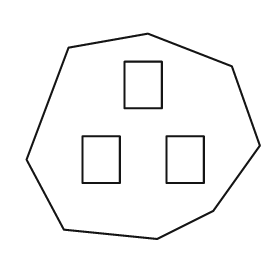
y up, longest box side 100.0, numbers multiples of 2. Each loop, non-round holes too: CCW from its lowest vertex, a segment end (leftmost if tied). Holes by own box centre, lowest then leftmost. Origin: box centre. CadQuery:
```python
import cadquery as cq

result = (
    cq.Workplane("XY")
    .moveTo(6.0, -44.0)
    .lineTo(30.0, -32.0)
    .lineTo(50.0, -4.0)
    .lineTo(38.0, 30.0)
    .lineTo(2.0, 44.0)
    .lineTo(-32.0, 38.0)
    .lineTo(-50.0, -10.0)
    .lineTo(-34.0, -40.0)
    .close()
    .moveTo(-26.0, -20.0)
    .lineTo(-10.0, -20.0)
    .lineTo(-10.0, 0.0)
    .lineTo(-26.0, 0.0)
    .close()
    .moveTo(10.0, -20.0)
    .lineTo(26.0, -20.0)
    .lineTo(26.0, 0.0)
    .lineTo(10.0, 0.0)
    .close()
    .moveTo(-8.0, 12.0)
    .lineTo(8.0, 12.0)
    .lineTo(8.0, 32.0)
    .lineTo(-8.0, 32.0)
    .close()
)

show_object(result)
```